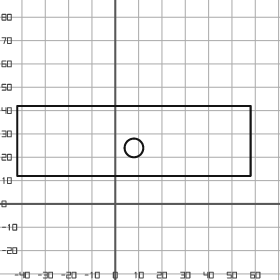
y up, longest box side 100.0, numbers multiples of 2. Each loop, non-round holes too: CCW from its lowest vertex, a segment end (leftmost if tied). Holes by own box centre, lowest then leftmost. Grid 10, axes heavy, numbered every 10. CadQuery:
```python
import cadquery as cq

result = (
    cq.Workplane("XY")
    .moveTo(-42.0, 12.0)
    .lineTo(58.0, 12.0)
    .lineTo(58.0, 42.0)
    .lineTo(-42.0, 42.0)
    .close()
    .moveTo(8.0, 24.0)
    .circle(4.0)
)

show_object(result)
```